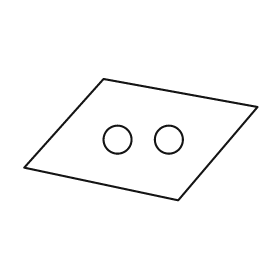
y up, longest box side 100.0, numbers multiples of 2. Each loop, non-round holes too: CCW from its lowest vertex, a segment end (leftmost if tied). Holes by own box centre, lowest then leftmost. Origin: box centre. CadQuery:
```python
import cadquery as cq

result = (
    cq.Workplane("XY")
    .moveTo(16.0, -26.0)
    .lineTo(50.0, 14.0)
    .lineTo(-16.0, 26.0)
    .lineTo(-50.0, -12.0)
    .close()
    .moveTo(-10.0, 0.0)
    .circle(6.0)
    .moveTo(12.0, 0.0)
    .circle(6.0)
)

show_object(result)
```